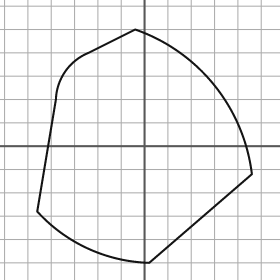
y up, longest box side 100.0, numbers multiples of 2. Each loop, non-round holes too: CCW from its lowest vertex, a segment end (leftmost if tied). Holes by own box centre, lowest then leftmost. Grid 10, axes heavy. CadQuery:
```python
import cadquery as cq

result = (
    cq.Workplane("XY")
    .moveTo(2.0, -50.0)
    .lineTo(46.0, -12.0)
    .threePointArc((30.0, 26.0), (-4.0, 50.0))
    .lineTo(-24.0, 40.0)
    .threePointArc((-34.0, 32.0), (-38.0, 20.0))
    .lineTo(-46.0, -28.0)
    .threePointArc((-24.0, -44.0), (2.0, -50.0))
    .close()
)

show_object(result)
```